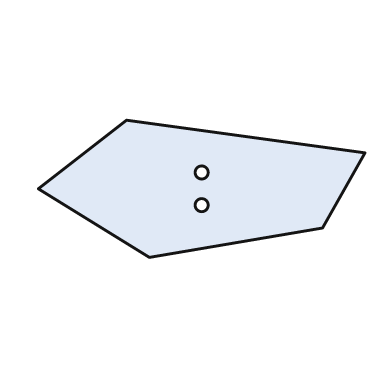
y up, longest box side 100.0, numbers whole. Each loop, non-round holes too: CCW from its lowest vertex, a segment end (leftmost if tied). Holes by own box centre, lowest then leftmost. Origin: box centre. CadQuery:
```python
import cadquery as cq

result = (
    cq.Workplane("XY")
    .moveTo(-16.0, -21.0)
    .lineTo(37.0, -12.0)
    .lineTo(50.0, 11.0)
    .lineTo(-23.0, 21.0)
    .lineTo(-50.0, 0.0)
    .close()
    .moveTo(0.0, -5.0)
    .circle(2.0)
    .moveTo(0.0, 5.0)
    .circle(2.0)
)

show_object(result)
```